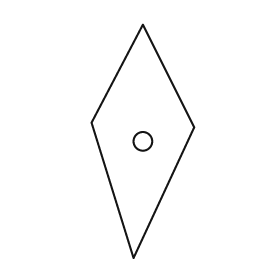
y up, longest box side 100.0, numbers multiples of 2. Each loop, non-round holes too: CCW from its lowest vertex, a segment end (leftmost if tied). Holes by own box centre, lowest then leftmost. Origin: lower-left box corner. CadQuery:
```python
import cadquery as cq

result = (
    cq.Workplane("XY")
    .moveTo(18.0, 0.0)
    .lineTo(44.0, 56.0)
    .lineTo(22.0, 100.0)
    .lineTo(0.0, 58.0)
    .close()
    .moveTo(22.0, 50.0)
    .circle(4.0)
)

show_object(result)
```